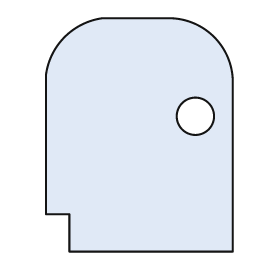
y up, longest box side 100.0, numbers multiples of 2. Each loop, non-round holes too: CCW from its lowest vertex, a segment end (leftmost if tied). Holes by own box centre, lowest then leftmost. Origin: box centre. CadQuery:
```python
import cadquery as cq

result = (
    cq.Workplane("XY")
    .moveTo(-30.0, -50.0)
    .lineTo(40.0, -50.0)
    .lineTo(40.0, 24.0)
    .threePointArc((32.0, 42.0), (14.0, 50.0))
    .lineTo(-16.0, 50.0)
    .threePointArc((-32.0, 42.0), (-40.0, 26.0))
    .lineTo(-40.0, -34.0)
    .lineTo(-30.0, -34.0)
    .close()
    .moveTo(24.0, 8.0)
    .circle(8.0)
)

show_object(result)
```